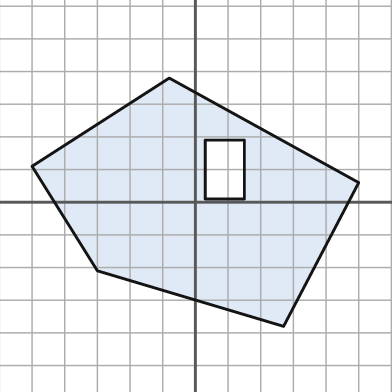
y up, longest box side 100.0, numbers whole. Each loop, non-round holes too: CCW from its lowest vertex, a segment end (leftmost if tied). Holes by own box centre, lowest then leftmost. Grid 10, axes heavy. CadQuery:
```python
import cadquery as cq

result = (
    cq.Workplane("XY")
    .moveTo(27.0, -38.0)
    .lineTo(50.0, 6.0)
    .lineTo(-8.0, 38.0)
    .lineTo(-50.0, 11.0)
    .lineTo(-30.0, -21.0)
    .close()
    .moveTo(3.0, 1.0)
    .lineTo(15.0, 1.0)
    .lineTo(15.0, 19.0)
    .lineTo(3.0, 19.0)
    .close()
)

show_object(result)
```